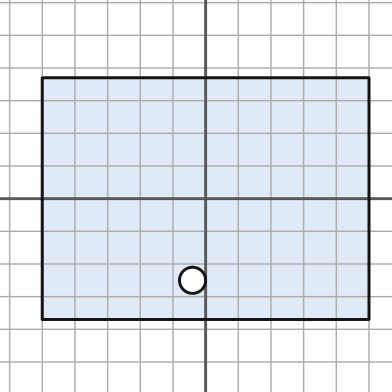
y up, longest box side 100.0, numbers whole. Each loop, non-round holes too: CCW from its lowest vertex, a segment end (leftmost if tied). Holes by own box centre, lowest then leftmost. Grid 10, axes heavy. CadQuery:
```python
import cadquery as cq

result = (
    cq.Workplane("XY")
    .moveTo(-50.0, -37.0)
    .lineTo(50.0, -37.0)
    .lineTo(50.0, 37.0)
    .lineTo(-50.0, 37.0)
    .close()
    .moveTo(-4.0, -25.0)
    .circle(4.0)
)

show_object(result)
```